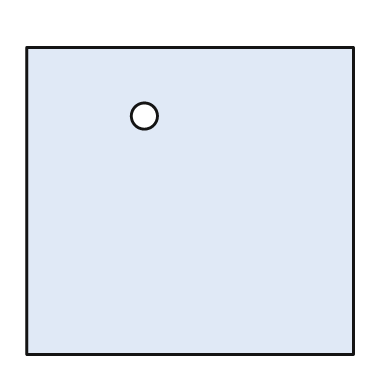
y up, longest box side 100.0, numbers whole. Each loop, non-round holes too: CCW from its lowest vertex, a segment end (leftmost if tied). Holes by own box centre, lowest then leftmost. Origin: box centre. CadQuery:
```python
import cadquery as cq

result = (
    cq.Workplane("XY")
    .moveTo(-50.0, -47.0)
    .lineTo(50.0, -47.0)
    .lineTo(50.0, 47.0)
    .lineTo(-50.0, 47.0)
    .close()
    .moveTo(-14.0, 26.0)
    .circle(4.0)
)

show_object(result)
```